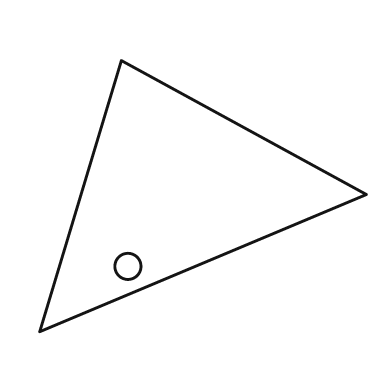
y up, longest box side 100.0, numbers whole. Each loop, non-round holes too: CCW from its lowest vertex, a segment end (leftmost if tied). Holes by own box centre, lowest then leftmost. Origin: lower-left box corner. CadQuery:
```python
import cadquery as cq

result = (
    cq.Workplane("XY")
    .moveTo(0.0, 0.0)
    .lineTo(100.0, 42.0)
    .lineTo(25.0, 83.0)
    .close()
    .moveTo(27.0, 20.0)
    .circle(4.0)
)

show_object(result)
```